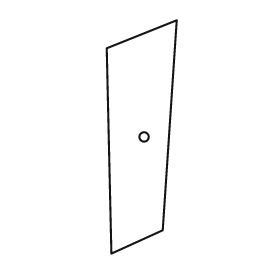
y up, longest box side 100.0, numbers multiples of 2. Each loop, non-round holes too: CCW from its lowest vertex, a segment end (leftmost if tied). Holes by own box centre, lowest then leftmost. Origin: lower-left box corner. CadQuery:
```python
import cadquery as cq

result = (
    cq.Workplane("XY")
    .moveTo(2.0, 0.0)
    .lineTo(24.0, 10.0)
    .lineTo(30.0, 100.0)
    .lineTo(0.0, 88.0)
    .close()
    .moveTo(16.0, 50.0)
    .circle(2.0)
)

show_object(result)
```